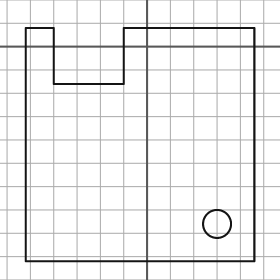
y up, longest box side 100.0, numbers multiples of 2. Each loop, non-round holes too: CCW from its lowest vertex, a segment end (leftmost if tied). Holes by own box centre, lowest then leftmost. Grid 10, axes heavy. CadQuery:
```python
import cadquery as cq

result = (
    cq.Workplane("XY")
    .moveTo(-52.0, -92.0)
    .lineTo(46.0, -92.0)
    .lineTo(46.0, 8.0)
    .lineTo(-10.0, 8.0)
    .lineTo(-10.0, -16.0)
    .lineTo(-40.0, -16.0)
    .lineTo(-40.0, 8.0)
    .lineTo(-52.0, 8.0)
    .close()
    .moveTo(30.0, -76.0)
    .circle(6.0)
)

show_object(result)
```